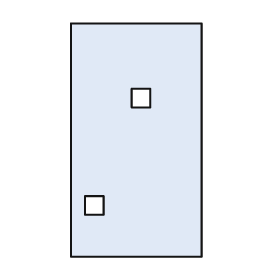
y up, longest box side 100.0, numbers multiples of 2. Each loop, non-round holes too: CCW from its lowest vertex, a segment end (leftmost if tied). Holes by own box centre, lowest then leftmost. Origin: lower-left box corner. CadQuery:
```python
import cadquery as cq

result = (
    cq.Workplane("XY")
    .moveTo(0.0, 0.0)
    .lineTo(56.0, 0.0)
    .lineTo(56.0, 100.0)
    .lineTo(0.0, 100.0)
    .close()
    .moveTo(6.0, 18.0)
    .lineTo(14.0, 18.0)
    .lineTo(14.0, 26.0)
    .lineTo(6.0, 26.0)
    .close()
    .moveTo(26.0, 64.0)
    .lineTo(34.0, 64.0)
    .lineTo(34.0, 72.0)
    .lineTo(26.0, 72.0)
    .close()
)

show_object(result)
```